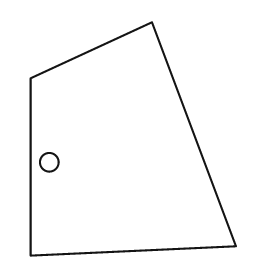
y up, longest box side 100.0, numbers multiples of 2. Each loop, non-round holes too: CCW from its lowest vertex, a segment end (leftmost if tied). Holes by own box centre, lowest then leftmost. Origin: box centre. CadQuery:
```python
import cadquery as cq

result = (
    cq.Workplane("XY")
    .moveTo(-44.0, -50.0)
    .lineTo(44.0, -46.0)
    .lineTo(8.0, 50.0)
    .lineTo(-44.0, 26.0)
    .close()
    .moveTo(-36.0, -10.0)
    .circle(4.0)
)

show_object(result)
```